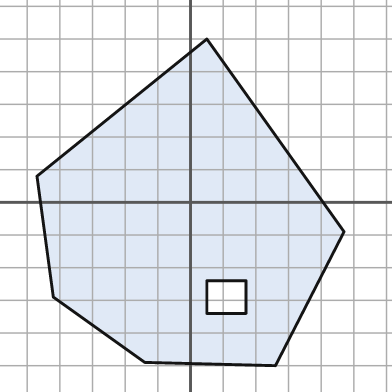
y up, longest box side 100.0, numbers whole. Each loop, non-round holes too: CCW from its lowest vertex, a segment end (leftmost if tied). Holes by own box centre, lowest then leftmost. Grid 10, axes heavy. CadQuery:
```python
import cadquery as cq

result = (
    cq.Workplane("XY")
    .moveTo(26.0, -50.0)
    .lineTo(47.0, -9.0)
    .lineTo(5.0, 50.0)
    .lineTo(-47.0, 8.0)
    .lineTo(-42.0, -29.0)
    .lineTo(-14.0, -49.0)
    .close()
    .moveTo(5.0, -34.0)
    .lineTo(17.0, -34.0)
    .lineTo(17.0, -24.0)
    .lineTo(5.0, -24.0)
    .close()
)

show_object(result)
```